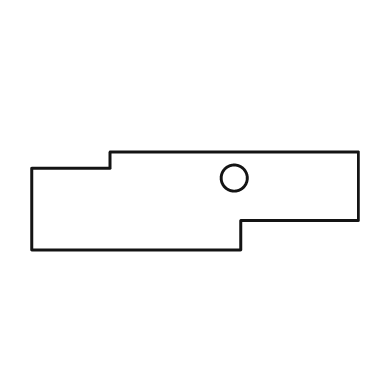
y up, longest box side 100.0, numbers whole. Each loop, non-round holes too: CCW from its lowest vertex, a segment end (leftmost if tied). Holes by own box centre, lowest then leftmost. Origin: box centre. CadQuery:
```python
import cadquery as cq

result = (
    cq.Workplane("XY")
    .moveTo(-50.0, -15.0)
    .lineTo(14.0, -15.0)
    .lineTo(14.0, -6.0)
    .lineTo(50.0, -6.0)
    .lineTo(50.0, 15.0)
    .lineTo(-26.0, 15.0)
    .lineTo(-26.0, 10.0)
    .lineTo(-50.0, 10.0)
    .close()
    .moveTo(12.0, 7.0)
    .circle(4.0)
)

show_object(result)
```